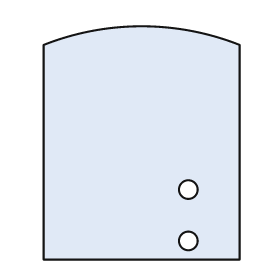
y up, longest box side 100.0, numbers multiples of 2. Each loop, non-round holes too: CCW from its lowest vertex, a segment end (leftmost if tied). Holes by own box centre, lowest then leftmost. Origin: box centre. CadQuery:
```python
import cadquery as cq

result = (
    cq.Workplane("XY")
    .moveTo(-42.0, -50.0)
    .lineTo(42.0, -50.0)
    .lineTo(42.0, 42.0)
    .threePointArc((0.0, 50.0), (-42.0, 42.0))
    .close()
    .moveTo(20.0, -42.0)
    .circle(4.0)
    .moveTo(20.0, -20.0)
    .circle(4.0)
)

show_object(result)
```